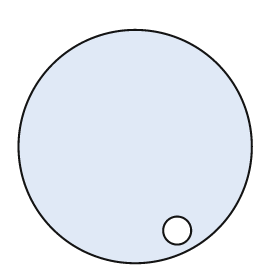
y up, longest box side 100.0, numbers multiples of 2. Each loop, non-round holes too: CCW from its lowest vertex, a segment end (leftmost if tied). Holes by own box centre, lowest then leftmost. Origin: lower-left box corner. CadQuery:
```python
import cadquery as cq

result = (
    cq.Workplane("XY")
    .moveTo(50.0, 50.0)
    .circle(50.0)
    .moveTo(68.0, 14.0)
    .circle(6.0)
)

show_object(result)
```